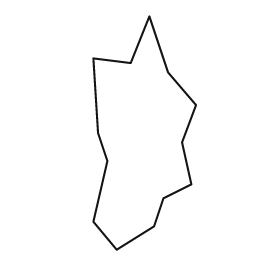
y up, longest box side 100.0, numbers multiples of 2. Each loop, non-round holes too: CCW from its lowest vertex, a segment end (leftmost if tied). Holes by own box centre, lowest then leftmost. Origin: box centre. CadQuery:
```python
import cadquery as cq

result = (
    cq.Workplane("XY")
    .moveTo(-12.0, -50.0)
    .lineTo(4.0, -40.0)
    .lineTo(8.0, -28.0)
    .lineTo(20.0, -22.0)
    .lineTo(16.0, -4.0)
    .lineTo(22.0, 12.0)
    .lineTo(10.0, 26.0)
    .lineTo(2.0, 50.0)
    .lineTo(-6.0, 30.0)
    .lineTo(-22.0, 32.0)
    .lineTo(-20.0, 0.0)
    .lineTo(-16.0, -12.0)
    .lineTo(-22.0, -38.0)
    .close()
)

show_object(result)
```